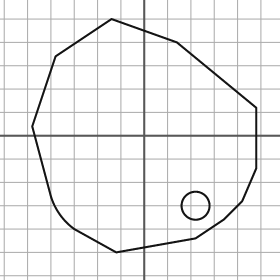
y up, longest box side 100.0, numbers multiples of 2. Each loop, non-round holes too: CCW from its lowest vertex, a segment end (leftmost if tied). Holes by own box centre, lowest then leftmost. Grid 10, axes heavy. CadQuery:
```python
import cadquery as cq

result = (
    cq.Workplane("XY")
    .moveTo(-12.0, -50.0)
    .lineTo(22.0, -44.0)
    .lineTo(34.0, -36.0)
    .lineTo(42.0, -28.0)
    .lineTo(48.0, -14.0)
    .lineTo(48.0, 12.0)
    .lineTo(14.0, 40.0)
    .lineTo(-14.0, 50.0)
    .lineTo(-38.0, 34.0)
    .lineTo(-48.0, 4.0)
    .lineTo(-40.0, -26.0)
    .threePointArc((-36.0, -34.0), (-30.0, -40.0))
    .close()
    .moveTo(22.0, -30.0)
    .circle(6.0)
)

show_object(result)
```